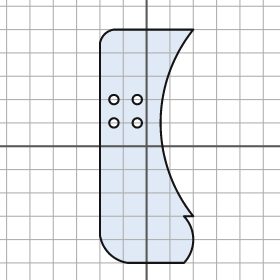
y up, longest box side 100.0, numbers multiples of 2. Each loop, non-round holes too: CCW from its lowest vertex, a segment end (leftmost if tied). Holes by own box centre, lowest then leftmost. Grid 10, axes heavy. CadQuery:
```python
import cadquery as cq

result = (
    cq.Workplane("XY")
    .moveTo(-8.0, -50.0)
    .lineTo(16.0, -50.0)
    .threePointArc((20.0, -40.0), (16.0, -30.0))
    .lineTo(20.0, -30.0)
    .threePointArc((6.0, 10.0), (20.0, 50.0))
    .lineTo(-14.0, 50.0)
    .threePointArc((-18.0, 48.0), (-20.0, 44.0))
    .lineTo(-20.0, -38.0)
    .threePointArc((-16.0, -46.0), (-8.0, -50.0))
    .close()
    .moveTo(-14.0, 10.0)
    .circle(2.0)
    .moveTo(-4.0, 10.0)
    .circle(2.0)
    .moveTo(-14.0, 20.0)
    .circle(2.0)
    .moveTo(-4.0, 20.0)
    .circle(2.0)
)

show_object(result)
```